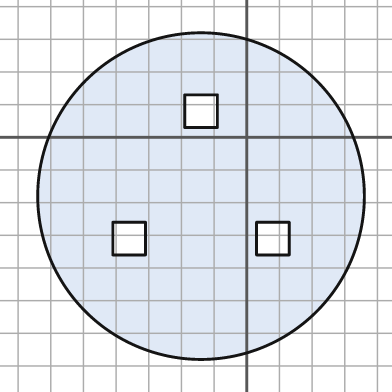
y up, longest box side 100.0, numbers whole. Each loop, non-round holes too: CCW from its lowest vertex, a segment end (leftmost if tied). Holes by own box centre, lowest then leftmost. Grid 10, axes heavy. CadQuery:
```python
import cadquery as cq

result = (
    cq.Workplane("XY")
    .moveTo(-14.0, -18.0)
    .circle(50.0)
    .moveTo(-41.0, -36.0)
    .lineTo(-31.0, -36.0)
    .lineTo(-31.0, -26.0)
    .lineTo(-41.0, -26.0)
    .close()
    .moveTo(3.0, -36.0)
    .lineTo(13.0, -36.0)
    .lineTo(13.0, -26.0)
    .lineTo(3.0, -26.0)
    .close()
    .moveTo(-19.0, 3.0)
    .lineTo(-9.0, 3.0)
    .lineTo(-9.0, 13.0)
    .lineTo(-19.0, 13.0)
    .close()
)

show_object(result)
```